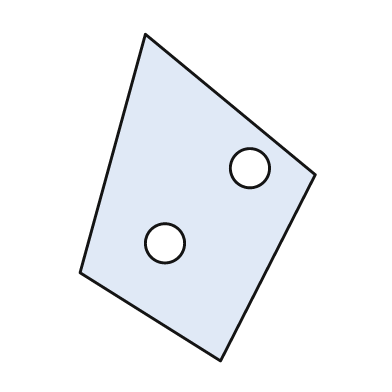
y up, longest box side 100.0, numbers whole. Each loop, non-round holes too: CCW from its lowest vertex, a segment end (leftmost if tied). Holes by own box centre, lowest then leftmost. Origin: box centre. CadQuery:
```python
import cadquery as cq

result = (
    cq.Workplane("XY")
    .moveTo(7.0, -50.0)
    .lineTo(36.0, 7.0)
    .lineTo(-16.0, 50.0)
    .lineTo(-36.0, -23.0)
    .close()
    .moveTo(-10.0, -14.0)
    .circle(6.0)
    .moveTo(16.0, 9.0)
    .circle(6.0)
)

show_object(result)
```